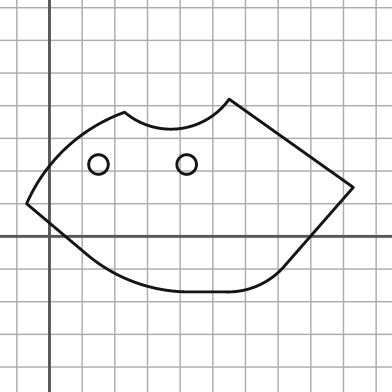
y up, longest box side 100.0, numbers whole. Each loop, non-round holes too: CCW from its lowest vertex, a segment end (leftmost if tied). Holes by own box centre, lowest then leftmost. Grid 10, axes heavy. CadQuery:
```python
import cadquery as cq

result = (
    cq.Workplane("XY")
    .moveTo(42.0, -17.0)
    .lineTo(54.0, -17.0)
    .threePointArc((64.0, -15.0), (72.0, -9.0))
    .lineTo(93.0, 15.0)
    .lineTo(55.0, 42.0)
    .threePointArc((40.0, 33.0), (23.0, 38.0))
    .threePointArc((5.0, 27.0), (-7.0, 10.0))
    .lineTo(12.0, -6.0)
    .threePointArc((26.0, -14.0), (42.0, -17.0))
    .close()
    .moveTo(15.0, 22.0)
    .circle(3.0)
    .moveTo(42.0, 22.0)
    .circle(3.0)
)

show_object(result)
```